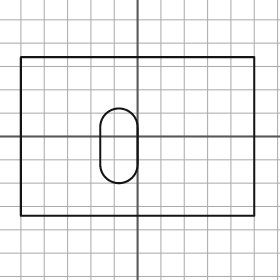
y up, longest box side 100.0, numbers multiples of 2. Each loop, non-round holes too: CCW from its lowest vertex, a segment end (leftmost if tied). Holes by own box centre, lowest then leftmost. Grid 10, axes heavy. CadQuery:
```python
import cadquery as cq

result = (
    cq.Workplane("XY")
    .moveTo(-50.0, -34.0)
    .lineTo(50.0, -34.0)
    .lineTo(50.0, 34.0)
    .lineTo(-50.0, 34.0)
    .close()
    .moveTo(-16.0, -12.0)
    .threePointArc((-8.0, -20.0), (0.0, -12.0))
    .lineTo(0.0, 4.0)
    .threePointArc((-8.0, 12.0), (-16.0, 4.0))
    .close()
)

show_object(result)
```